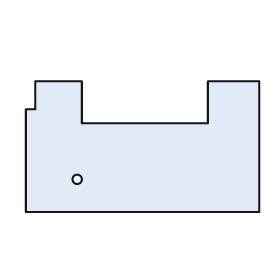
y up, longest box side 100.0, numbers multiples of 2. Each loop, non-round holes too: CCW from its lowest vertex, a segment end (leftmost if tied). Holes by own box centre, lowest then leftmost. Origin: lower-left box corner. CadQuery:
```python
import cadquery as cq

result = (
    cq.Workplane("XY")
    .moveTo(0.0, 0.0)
    .lineTo(100.0, 0.0)
    .lineTo(100.0, 56.0)
    .lineTo(78.0, 56.0)
    .lineTo(78.0, 38.0)
    .lineTo(24.0, 38.0)
    .lineTo(24.0, 56.0)
    .lineTo(4.0, 56.0)
    .lineTo(4.0, 44.0)
    .lineTo(0.0, 44.0)
    .close()
    .moveTo(22.0, 14.0)
    .circle(2.0)
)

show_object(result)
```